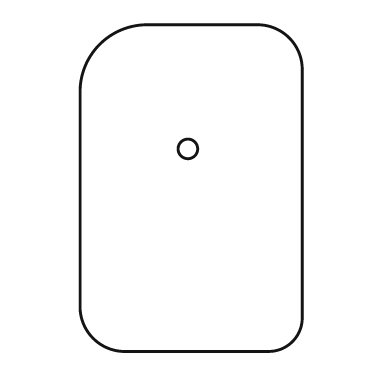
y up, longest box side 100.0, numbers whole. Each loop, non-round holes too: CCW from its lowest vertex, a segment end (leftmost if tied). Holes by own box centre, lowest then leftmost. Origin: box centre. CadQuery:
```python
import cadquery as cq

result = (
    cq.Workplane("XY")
    .moveTo(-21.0, -50.0)
    .lineTo(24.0, -50.0)
    .threePointArc((31.0, -47.0), (34.0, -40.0))
    .lineTo(34.0, 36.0)
    .threePointArc((30.0, 46.0), (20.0, 50.0))
    .lineTo(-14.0, 50.0)
    .threePointArc((-28.0, 44.0), (-34.0, 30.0))
    .lineTo(-34.0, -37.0)
    .threePointArc((-30.0, -46.0), (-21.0, -50.0))
    .close()
    .moveTo(-1.0, 12.0)
    .circle(3.0)
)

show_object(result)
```